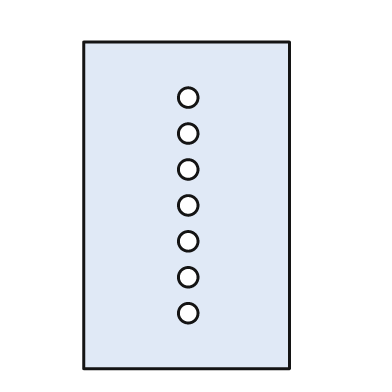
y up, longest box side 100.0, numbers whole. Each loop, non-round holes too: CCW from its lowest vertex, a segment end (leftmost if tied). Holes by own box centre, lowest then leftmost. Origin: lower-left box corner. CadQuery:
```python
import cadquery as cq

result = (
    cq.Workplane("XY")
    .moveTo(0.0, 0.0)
    .lineTo(63.0, 0.0)
    .lineTo(63.0, 100.0)
    .lineTo(0.0, 100.0)
    .close()
    .moveTo(32.0, 17.0)
    .circle(3.0)
    .moveTo(32.0, 28.0)
    .circle(3.0)
    .moveTo(32.0, 39.0)
    .circle(3.0)
    .moveTo(32.0, 50.0)
    .circle(3.0)
    .moveTo(32.0, 61.0)
    .circle(3.0)
    .moveTo(32.0, 72.0)
    .circle(3.0)
    .moveTo(32.0, 83.0)
    .circle(3.0)
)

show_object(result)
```